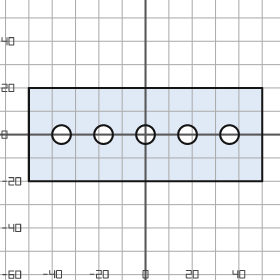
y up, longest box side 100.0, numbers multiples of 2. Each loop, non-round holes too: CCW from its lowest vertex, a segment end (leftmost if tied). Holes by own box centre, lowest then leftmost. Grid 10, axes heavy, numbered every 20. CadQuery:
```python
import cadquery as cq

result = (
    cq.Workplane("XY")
    .moveTo(-50.0, -20.0)
    .lineTo(50.0, -20.0)
    .lineTo(50.0, 20.0)
    .lineTo(-50.0, 20.0)
    .close()
    .moveTo(-36.0, 0.0)
    .circle(4.0)
    .moveTo(-18.0, 0.0)
    .circle(4.0)
    .moveTo(0.0, 0.0)
    .circle(4.0)
    .moveTo(18.0, 0.0)
    .circle(4.0)
    .moveTo(36.0, 0.0)
    .circle(4.0)
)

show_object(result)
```